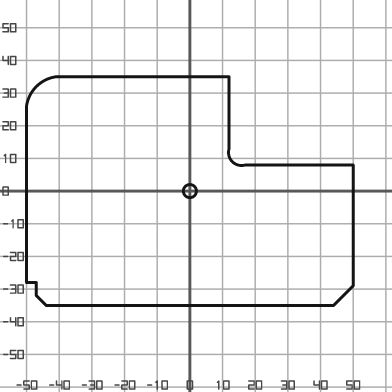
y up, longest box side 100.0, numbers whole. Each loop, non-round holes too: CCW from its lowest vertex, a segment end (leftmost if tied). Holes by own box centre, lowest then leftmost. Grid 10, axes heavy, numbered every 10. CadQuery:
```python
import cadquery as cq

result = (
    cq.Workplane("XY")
    .moveTo(-44.0, -35.0)
    .lineTo(44.0, -35.0)
    .lineTo(50.0, -29.0)
    .lineTo(50.0, 8.0)
    .lineTo(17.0, 8.0)
    .threePointArc((13.0, 9.0), (12.0, 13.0))
    .lineTo(12.0, 35.0)
    .lineTo(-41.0, 35.0)
    .threePointArc((-47.0, 32.0), (-50.0, 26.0))
    .lineTo(-50.0, -28.0)
    .lineTo(-47.0, -28.0)
    .lineTo(-47.0, -32.0)
    .close()
    .moveTo(0.0, 0.0)
    .circle(2.0)
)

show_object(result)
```